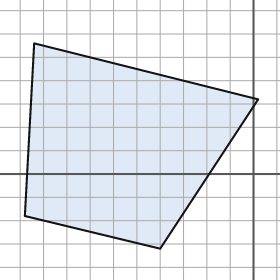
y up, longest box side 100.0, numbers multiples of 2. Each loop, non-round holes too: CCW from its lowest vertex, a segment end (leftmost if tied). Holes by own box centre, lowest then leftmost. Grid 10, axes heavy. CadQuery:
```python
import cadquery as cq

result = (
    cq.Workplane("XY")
    .moveTo(-40.0, -32.0)
    .lineTo(2.0, 32.0)
    .lineTo(-94.0, 56.0)
    .lineTo(-98.0, -18.0)
    .close()
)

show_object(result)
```